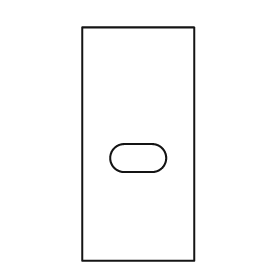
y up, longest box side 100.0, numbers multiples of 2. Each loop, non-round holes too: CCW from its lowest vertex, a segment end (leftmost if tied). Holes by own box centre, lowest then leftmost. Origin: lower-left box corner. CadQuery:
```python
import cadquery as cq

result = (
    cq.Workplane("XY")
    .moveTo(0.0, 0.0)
    .lineTo(48.0, 0.0)
    .lineTo(48.0, 100.0)
    .lineTo(0.0, 100.0)
    .close()
    .moveTo(18.0, 38.0)
    .lineTo(30.0, 38.0)
    .threePointArc((36.0, 44.0), (30.0, 50.0))
    .lineTo(18.0, 50.0)
    .threePointArc((12.0, 44.0), (18.0, 38.0))
    .close()
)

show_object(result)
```